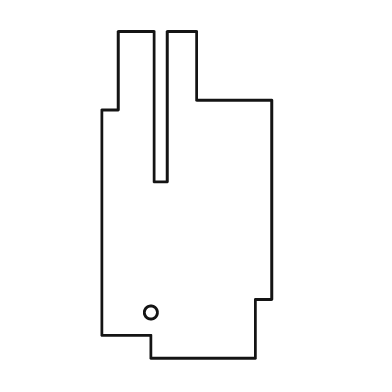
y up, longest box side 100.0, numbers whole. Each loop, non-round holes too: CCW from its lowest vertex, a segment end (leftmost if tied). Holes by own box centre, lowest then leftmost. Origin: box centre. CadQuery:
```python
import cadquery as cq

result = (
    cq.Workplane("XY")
    .moveTo(-11.0, -50.0)
    .lineTo(21.0, -50.0)
    .lineTo(21.0, -32.0)
    .lineTo(26.0, -32.0)
    .lineTo(26.0, 29.0)
    .lineTo(3.0, 29.0)
    .lineTo(3.0, 50.0)
    .lineTo(-6.0, 50.0)
    .lineTo(-6.0, 4.0)
    .lineTo(-10.0, 4.0)
    .lineTo(-10.0, 50.0)
    .lineTo(-21.0, 50.0)
    .lineTo(-21.0, 26.0)
    .lineTo(-26.0, 26.0)
    .lineTo(-26.0, -43.0)
    .lineTo(-11.0, -43.0)
    .close()
    .moveTo(-11.0, -36.0)
    .circle(2.0)
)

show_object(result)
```